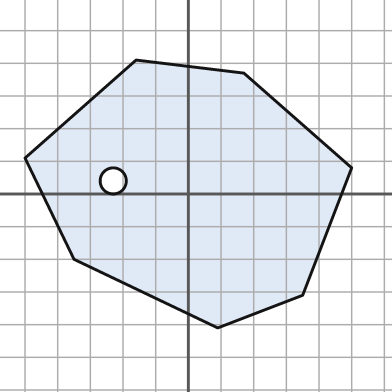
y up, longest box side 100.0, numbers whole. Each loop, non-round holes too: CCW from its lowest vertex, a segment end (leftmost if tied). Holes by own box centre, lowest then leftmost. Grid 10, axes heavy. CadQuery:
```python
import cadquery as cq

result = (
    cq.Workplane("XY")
    .moveTo(9.0, -41.0)
    .lineTo(35.0, -31.0)
    .lineTo(50.0, 8.0)
    .lineTo(17.0, 37.0)
    .lineTo(-16.0, 41.0)
    .lineTo(-50.0, 11.0)
    .lineTo(-35.0, -20.0)
    .close()
    .moveTo(-23.0, 4.0)
    .circle(4.0)
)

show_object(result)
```